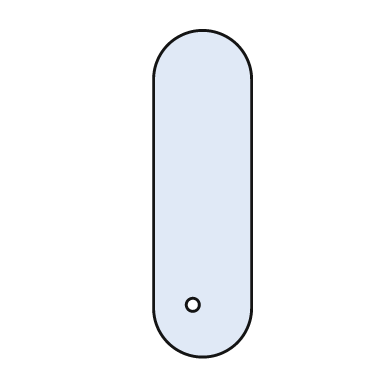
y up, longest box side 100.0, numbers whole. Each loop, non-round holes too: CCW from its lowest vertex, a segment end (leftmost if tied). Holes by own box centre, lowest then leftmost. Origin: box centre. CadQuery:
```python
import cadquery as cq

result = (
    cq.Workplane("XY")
    .moveTo(-15.0, -35.0)
    .threePointArc((0.0, -50.0), (15.0, -35.0))
    .lineTo(15.0, 35.0)
    .threePointArc((0.0, 50.0), (-15.0, 35.0))
    .close()
    .moveTo(-3.0, -34.0)
    .circle(2.0)
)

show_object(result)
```